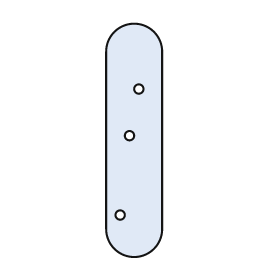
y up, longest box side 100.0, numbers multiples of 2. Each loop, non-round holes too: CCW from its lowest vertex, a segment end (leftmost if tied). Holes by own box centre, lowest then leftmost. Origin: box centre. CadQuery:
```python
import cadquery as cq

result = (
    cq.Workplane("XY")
    .moveTo(-12.0, -38.0)
    .threePointArc((0.0, -50.0), (12.0, -38.0))
    .lineTo(12.0, 38.0)
    .threePointArc((0.0, 50.0), (-12.0, 38.0))
    .close()
    .moveTo(-6.0, -32.0)
    .circle(2.0)
    .moveTo(-2.0, 2.0)
    .circle(2.0)
    .moveTo(2.0, 22.0)
    .circle(2.0)
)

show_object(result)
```